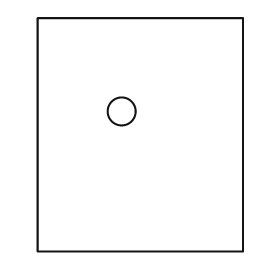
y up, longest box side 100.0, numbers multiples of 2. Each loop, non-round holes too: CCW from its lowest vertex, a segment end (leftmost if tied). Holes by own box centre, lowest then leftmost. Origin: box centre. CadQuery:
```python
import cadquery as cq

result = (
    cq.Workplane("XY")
    .moveTo(-44.0, -50.0)
    .lineTo(44.0, -50.0)
    .lineTo(44.0, 50.0)
    .lineTo(-44.0, 50.0)
    .close()
    .moveTo(-8.0, 10.0)
    .circle(6.0)
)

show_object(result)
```